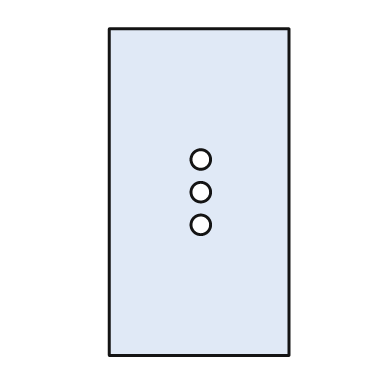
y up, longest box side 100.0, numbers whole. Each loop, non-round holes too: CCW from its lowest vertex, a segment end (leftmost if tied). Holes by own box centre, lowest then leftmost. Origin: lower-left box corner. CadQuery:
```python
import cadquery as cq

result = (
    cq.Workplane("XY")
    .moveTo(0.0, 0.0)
    .lineTo(55.0, 0.0)
    .lineTo(55.0, 100.0)
    .lineTo(0.0, 100.0)
    .close()
    .moveTo(28.0, 40.0)
    .circle(3.0)
    .moveTo(28.0, 50.0)
    .circle(3.0)
    .moveTo(28.0, 60.0)
    .circle(3.0)
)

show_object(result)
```